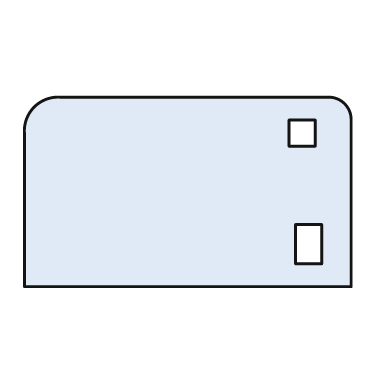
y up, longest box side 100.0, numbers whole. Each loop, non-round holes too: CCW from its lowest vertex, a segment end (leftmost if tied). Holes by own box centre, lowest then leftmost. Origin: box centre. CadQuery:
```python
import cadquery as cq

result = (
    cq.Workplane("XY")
    .moveTo(-50.0, -29.0)
    .lineTo(50.0, -29.0)
    .lineTo(50.0, 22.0)
    .threePointArc((48.0, 27.0), (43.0, 29.0))
    .lineTo(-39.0, 29.0)
    .threePointArc((-47.0, 26.0), (-50.0, 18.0))
    .close()
    .moveTo(33.0, -22.0)
    .lineTo(41.0, -22.0)
    .lineTo(41.0, -10.0)
    .lineTo(33.0, -10.0)
    .close()
    .moveTo(31.0, 14.0)
    .lineTo(39.0, 14.0)
    .lineTo(39.0, 22.0)
    .lineTo(31.0, 22.0)
    .close()
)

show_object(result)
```